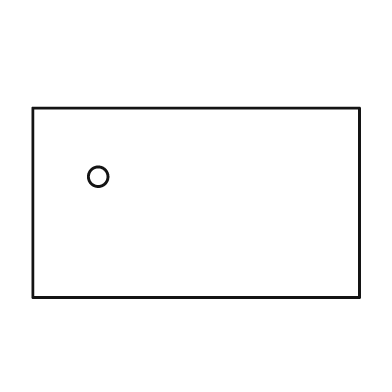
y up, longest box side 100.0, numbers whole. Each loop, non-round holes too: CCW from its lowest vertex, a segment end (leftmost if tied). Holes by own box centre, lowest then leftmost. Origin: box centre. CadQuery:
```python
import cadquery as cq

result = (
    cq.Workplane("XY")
    .moveTo(-50.0, -29.0)
    .lineTo(50.0, -29.0)
    .lineTo(50.0, 29.0)
    .lineTo(-50.0, 29.0)
    .close()
    .moveTo(-30.0, 8.0)
    .circle(3.0)
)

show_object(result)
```